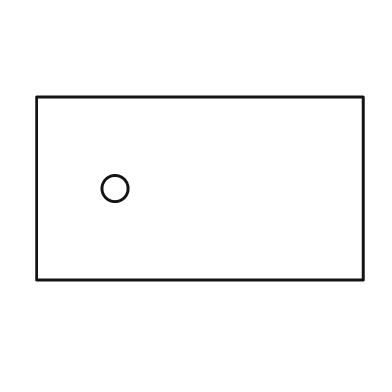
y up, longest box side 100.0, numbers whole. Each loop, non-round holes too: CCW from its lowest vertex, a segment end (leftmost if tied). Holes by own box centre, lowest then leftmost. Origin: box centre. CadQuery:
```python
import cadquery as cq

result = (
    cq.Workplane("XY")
    .moveTo(-50.0, -28.0)
    .lineTo(50.0, -28.0)
    .lineTo(50.0, 28.0)
    .lineTo(-50.0, 28.0)
    .close()
    .moveTo(-26.0, 0.0)
    .circle(4.0)
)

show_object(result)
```